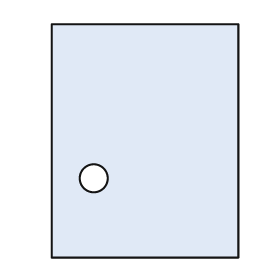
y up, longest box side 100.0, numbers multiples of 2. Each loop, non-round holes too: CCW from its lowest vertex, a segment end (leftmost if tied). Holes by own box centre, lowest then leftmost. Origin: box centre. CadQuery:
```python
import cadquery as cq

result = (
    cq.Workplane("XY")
    .moveTo(-40.0, -50.0)
    .lineTo(40.0, -50.0)
    .lineTo(40.0, 50.0)
    .lineTo(-40.0, 50.0)
    .close()
    .moveTo(-22.0, -16.0)
    .circle(6.0)
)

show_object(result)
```